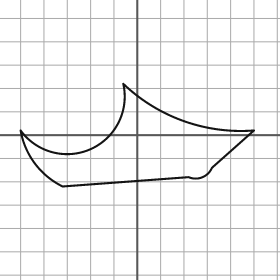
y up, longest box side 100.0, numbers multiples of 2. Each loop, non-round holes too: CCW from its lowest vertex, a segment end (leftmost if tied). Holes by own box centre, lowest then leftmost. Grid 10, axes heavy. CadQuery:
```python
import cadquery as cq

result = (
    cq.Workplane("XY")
    .moveTo(-32.0, -22.0)
    .lineTo(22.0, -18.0)
    .threePointArc((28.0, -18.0), (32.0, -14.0))
    .lineTo(50.0, 2.0)
    .threePointArc((20.0, 6.0), (-6.0, 22.0))
    .threePointArc((-20.0, -6.0), (-50.0, 2.0))
    .threePointArc((-44.0, -12.0), (-32.0, -22.0))
    .close()
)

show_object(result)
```